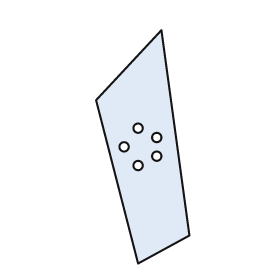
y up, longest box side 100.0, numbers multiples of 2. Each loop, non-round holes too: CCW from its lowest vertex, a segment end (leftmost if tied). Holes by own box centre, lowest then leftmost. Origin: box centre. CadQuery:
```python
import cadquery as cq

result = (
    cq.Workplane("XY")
    .moveTo(-2.0, -50.0)
    .lineTo(20.0, -38.0)
    .lineTo(8.0, 50.0)
    .lineTo(-20.0, 20.0)
    .close()
    .moveTo(-2.0, -8.0)
    .circle(2.0)
    .moveTo(6.0, -4.0)
    .circle(2.0)
    .moveTo(-8.0, 0.0)
    .circle(2.0)
    .moveTo(6.0, 4.0)
    .circle(2.0)
    .moveTo(-2.0, 8.0)
    .circle(2.0)
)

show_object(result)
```